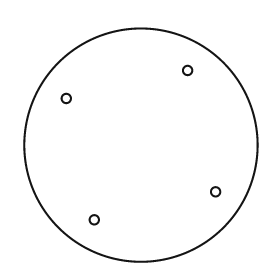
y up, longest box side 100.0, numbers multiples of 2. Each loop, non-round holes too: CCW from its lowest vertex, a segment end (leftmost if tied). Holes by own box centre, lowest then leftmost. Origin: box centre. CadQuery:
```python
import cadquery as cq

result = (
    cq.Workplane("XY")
    .moveTo(0.0, 0.0)
    .circle(50.0)
    .moveTo(-20.0, -32.0)
    .circle(2.0)
    .moveTo(32.0, -20.0)
    .circle(2.0)
    .moveTo(-32.0, 20.0)
    .circle(2.0)
    .moveTo(20.0, 32.0)
    .circle(2.0)
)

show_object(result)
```